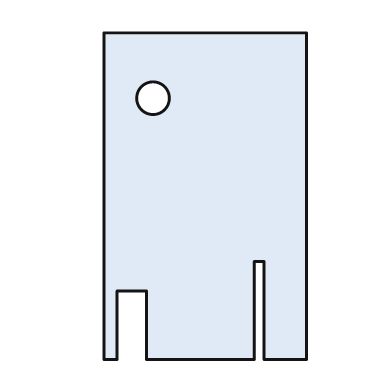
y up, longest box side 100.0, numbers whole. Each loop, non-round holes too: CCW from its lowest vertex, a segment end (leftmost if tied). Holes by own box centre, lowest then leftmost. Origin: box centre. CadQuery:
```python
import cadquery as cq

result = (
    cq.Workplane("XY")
    .moveTo(-31.0, -50.0)
    .lineTo(-27.0, -50.0)
    .lineTo(-27.0, -29.0)
    .lineTo(-18.0, -29.0)
    .lineTo(-18.0, -50.0)
    .lineTo(15.0, -50.0)
    .lineTo(15.0, -20.0)
    .lineTo(18.0, -20.0)
    .lineTo(18.0, -50.0)
    .lineTo(31.0, -50.0)
    .lineTo(31.0, 50.0)
    .lineTo(-31.0, 50.0)
    .close()
    .moveTo(-16.0, 30.0)
    .circle(5.0)
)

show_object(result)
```